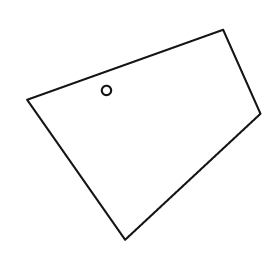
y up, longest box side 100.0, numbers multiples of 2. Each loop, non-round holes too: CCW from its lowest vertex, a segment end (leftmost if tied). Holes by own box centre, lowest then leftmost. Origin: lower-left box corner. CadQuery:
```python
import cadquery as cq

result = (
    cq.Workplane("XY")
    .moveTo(42.0, 0.0)
    .lineTo(100.0, 54.0)
    .lineTo(84.0, 90.0)
    .lineTo(0.0, 60.0)
    .close()
    .moveTo(34.0, 64.0)
    .circle(2.0)
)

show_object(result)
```